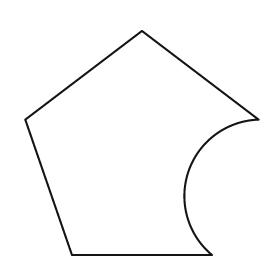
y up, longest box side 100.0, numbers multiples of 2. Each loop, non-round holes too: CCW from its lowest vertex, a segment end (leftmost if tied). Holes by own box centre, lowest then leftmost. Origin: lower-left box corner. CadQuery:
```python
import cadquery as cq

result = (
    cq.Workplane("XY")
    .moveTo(20.0, 0.0)
    .lineTo(80.0, 0.0)
    .threePointArc((70.0, 36.0), (100.0, 58.0))
    .lineTo(50.0, 96.0)
    .lineTo(0.0, 58.0)
    .close()
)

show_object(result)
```